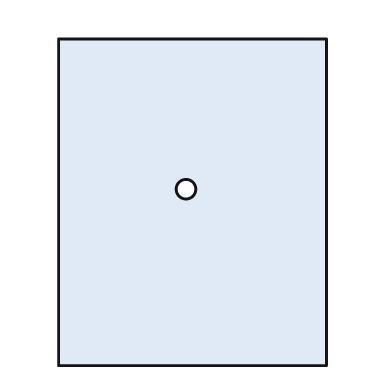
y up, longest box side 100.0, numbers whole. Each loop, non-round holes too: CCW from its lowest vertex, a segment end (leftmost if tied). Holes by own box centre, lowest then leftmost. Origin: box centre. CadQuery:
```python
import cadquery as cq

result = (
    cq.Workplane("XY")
    .moveTo(-41.0, -50.0)
    .lineTo(41.0, -50.0)
    .lineTo(41.0, 50.0)
    .lineTo(-41.0, 50.0)
    .close()
    .moveTo(-2.0, 4.0)
    .circle(3.0)
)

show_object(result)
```